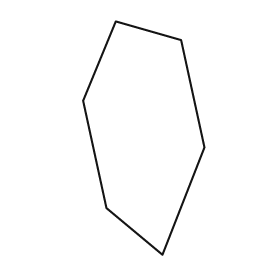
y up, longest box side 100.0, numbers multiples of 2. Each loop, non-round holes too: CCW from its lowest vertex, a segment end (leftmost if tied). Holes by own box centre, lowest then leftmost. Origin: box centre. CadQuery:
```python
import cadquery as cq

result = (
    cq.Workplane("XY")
    .moveTo(8.0, -50.0)
    .lineTo(26.0, -4.0)
    .lineTo(16.0, 42.0)
    .lineTo(-12.0, 50.0)
    .lineTo(-26.0, 16.0)
    .lineTo(-16.0, -30.0)
    .close()
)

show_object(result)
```